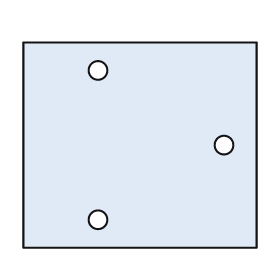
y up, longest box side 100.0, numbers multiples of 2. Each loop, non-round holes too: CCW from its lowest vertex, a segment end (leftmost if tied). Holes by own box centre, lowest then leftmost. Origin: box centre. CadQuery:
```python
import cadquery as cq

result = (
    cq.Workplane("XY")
    .moveTo(-50.0, -44.0)
    .lineTo(50.0, -44.0)
    .lineTo(50.0, 44.0)
    .lineTo(-50.0, 44.0)
    .close()
    .moveTo(-18.0, -32.0)
    .circle(4.0)
    .moveTo(36.0, 0.0)
    .circle(4.0)
    .moveTo(-18.0, 32.0)
    .circle(4.0)
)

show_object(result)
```